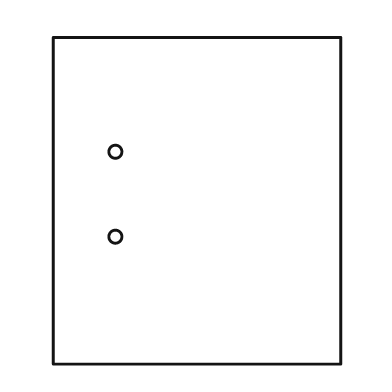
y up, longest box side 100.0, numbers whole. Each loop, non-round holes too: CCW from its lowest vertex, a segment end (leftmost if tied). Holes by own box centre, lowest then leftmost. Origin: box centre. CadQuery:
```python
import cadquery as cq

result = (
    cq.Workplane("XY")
    .moveTo(-44.0, -50.0)
    .lineTo(44.0, -50.0)
    .lineTo(44.0, 50.0)
    .lineTo(-44.0, 50.0)
    .close()
    .moveTo(-25.0, -11.0)
    .circle(2.0)
    .moveTo(-25.0, 15.0)
    .circle(2.0)
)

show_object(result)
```